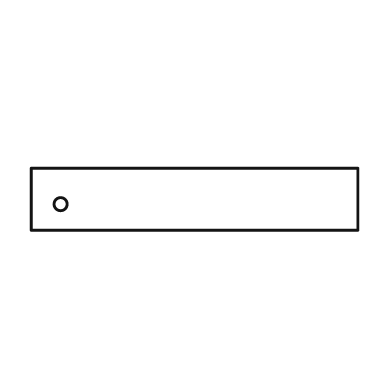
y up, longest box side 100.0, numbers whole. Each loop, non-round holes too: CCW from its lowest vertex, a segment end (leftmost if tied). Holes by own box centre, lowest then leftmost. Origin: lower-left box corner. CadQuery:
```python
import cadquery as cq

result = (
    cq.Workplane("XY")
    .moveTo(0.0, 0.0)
    .lineTo(100.0, 0.0)
    .lineTo(100.0, 19.0)
    .lineTo(0.0, 19.0)
    .close()
    .moveTo(9.0, 8.0)
    .circle(2.0)
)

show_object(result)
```